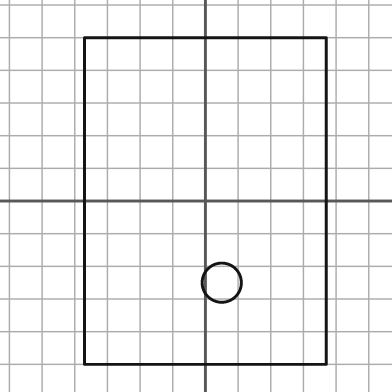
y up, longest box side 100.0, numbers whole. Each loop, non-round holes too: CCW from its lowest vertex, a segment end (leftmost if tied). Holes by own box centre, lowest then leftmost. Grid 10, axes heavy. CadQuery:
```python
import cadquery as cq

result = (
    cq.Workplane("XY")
    .moveTo(-37.0, -50.0)
    .lineTo(37.0, -50.0)
    .lineTo(37.0, 50.0)
    .lineTo(-37.0, 50.0)
    .close()
    .moveTo(5.0, -25.0)
    .circle(6.0)
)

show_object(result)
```